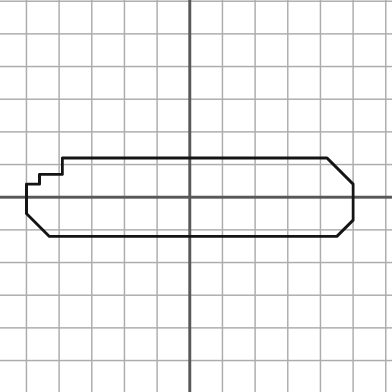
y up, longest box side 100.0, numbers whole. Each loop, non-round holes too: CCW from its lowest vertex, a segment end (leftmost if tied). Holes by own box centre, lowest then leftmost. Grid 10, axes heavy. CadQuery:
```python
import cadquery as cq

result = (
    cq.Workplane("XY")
    .moveTo(-43.0, -12.0)
    .lineTo(45.0, -12.0)
    .lineTo(50.0, -7.0)
    .lineTo(50.0, 4.0)
    .lineTo(42.0, 12.0)
    .lineTo(-39.0, 12.0)
    .lineTo(-39.0, 7.0)
    .lineTo(-46.0, 7.0)
    .lineTo(-46.0, 4.0)
    .lineTo(-50.0, 4.0)
    .lineTo(-50.0, -5.0)
    .close()
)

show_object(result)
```